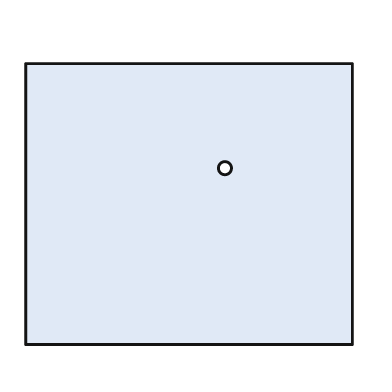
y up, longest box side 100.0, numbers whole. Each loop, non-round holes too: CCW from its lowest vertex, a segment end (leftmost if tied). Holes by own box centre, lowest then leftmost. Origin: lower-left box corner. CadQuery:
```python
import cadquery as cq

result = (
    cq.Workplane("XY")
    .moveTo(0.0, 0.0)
    .lineTo(100.0, 0.0)
    .lineTo(100.0, 86.0)
    .lineTo(0.0, 86.0)
    .close()
    .moveTo(61.0, 54.0)
    .circle(2.0)
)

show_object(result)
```